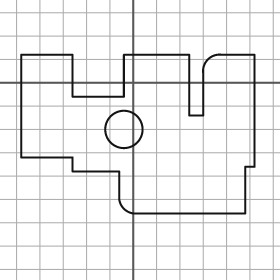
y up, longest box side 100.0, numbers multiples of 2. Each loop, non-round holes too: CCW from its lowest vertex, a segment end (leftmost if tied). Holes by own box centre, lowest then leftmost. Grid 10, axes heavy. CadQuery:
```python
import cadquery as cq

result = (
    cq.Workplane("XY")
    .moveTo(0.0, -56.0)
    .lineTo(48.0, -56.0)
    .lineTo(48.0, -36.0)
    .lineTo(52.0, -36.0)
    .lineTo(52.0, 12.0)
    .lineTo(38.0, 12.0)
    .threePointArc((32.0, 10.0), (30.0, 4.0))
    .lineTo(30.0, -14.0)
    .lineTo(24.0, -14.0)
    .lineTo(24.0, 12.0)
    .lineTo(-4.0, 12.0)
    .lineTo(-4.0, -6.0)
    .lineTo(-26.0, -6.0)
    .lineTo(-26.0, 12.0)
    .lineTo(-48.0, 12.0)
    .lineTo(-48.0, -32.0)
    .lineTo(-26.0, -32.0)
    .lineTo(-26.0, -38.0)
    .lineTo(-6.0, -38.0)
    .lineTo(-6.0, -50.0)
    .threePointArc((-4.0, -54.0), (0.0, -56.0))
    .close()
    .moveTo(-4.0, -20.0)
    .circle(8.0)
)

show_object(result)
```